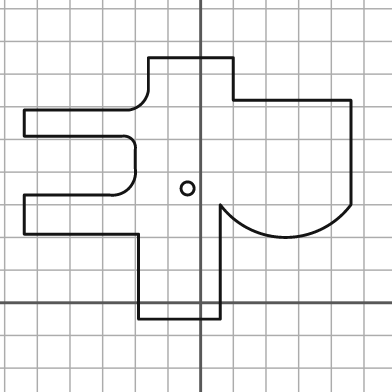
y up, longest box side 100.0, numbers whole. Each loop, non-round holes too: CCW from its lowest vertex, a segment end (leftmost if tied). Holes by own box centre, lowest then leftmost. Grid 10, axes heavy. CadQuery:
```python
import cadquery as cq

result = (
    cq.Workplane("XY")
    .moveTo(-19.0, -5.0)
    .lineTo(6.0, -5.0)
    .lineTo(6.0, 30.0)
    .threePointArc((26.0, 20.0), (46.0, 30.0))
    .lineTo(46.0, 62.0)
    .lineTo(10.0, 62.0)
    .lineTo(10.0, 75.0)
    .lineTo(-16.0, 75.0)
    .lineTo(-16.0, 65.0)
    .threePointArc((-18.0, 61.0), (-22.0, 59.0))
    .lineTo(-54.0, 59.0)
    .lineTo(-54.0, 51.0)
    .lineTo(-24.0, 51.0)
    .threePointArc((-21.0, 50.0), (-20.0, 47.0))
    .lineTo(-20.0, 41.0)
    .threePointArc((-22.0, 35.0), (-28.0, 33.0))
    .lineTo(-54.0, 33.0)
    .lineTo(-54.0, 21.0)
    .lineTo(-19.0, 21.0)
    .close()
    .moveTo(-4.0, 35.0)
    .circle(2.0)
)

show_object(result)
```